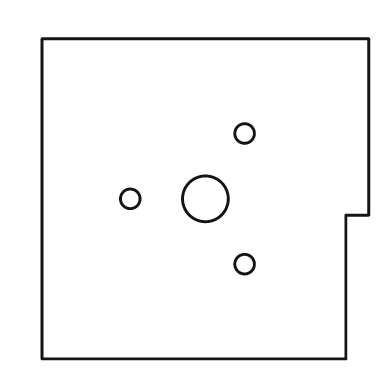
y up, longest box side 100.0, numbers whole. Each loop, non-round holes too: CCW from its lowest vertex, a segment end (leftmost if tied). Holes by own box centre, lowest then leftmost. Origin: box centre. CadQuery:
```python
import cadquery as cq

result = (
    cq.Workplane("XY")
    .moveTo(-50.0, -49.0)
    .lineTo(43.0, -49.0)
    .lineTo(43.0, -5.0)
    .lineTo(50.0, -5.0)
    .lineTo(50.0, 49.0)
    .lineTo(-50.0, 49.0)
    .close()
    .moveTo(12.0, -20.0)
    .circle(3.0)
    .moveTo(-23.0, 0.0)
    .circle(3.0)
    .moveTo(0.0, 0.0)
    .circle(7.0)
    .moveTo(12.0, 20.0)
    .circle(3.0)
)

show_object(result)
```